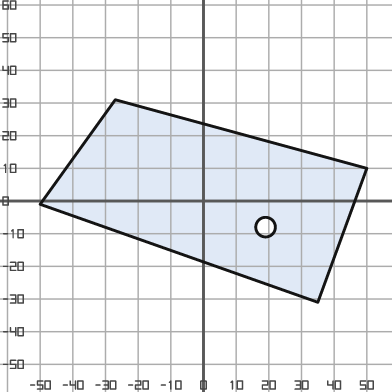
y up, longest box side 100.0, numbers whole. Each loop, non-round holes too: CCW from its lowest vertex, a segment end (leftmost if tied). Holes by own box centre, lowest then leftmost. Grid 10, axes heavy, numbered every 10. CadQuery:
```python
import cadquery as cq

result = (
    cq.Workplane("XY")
    .moveTo(35.0, -31.0)
    .lineTo(50.0, 10.0)
    .lineTo(-27.0, 31.0)
    .lineTo(-50.0, -1.0)
    .close()
    .moveTo(19.0, -8.0)
    .circle(3.0)
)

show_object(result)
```